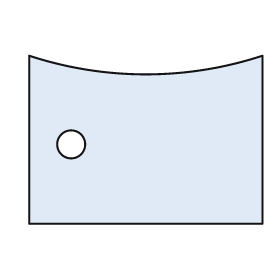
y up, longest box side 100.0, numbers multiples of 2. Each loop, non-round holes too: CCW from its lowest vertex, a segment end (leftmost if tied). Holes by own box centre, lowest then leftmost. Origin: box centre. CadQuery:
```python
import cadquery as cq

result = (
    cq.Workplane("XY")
    .moveTo(-50.0, -36.0)
    .lineTo(50.0, -36.0)
    .lineTo(50.0, 36.0)
    .threePointArc((0.0, 28.0), (-50.0, 36.0))
    .close()
    .moveTo(-32.0, -2.0)
    .circle(6.0)
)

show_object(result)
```